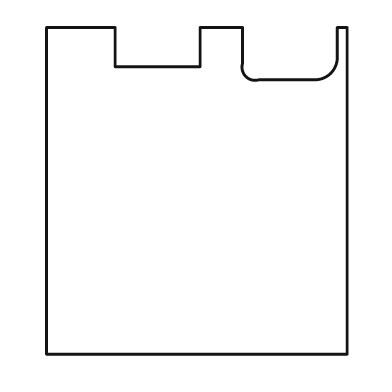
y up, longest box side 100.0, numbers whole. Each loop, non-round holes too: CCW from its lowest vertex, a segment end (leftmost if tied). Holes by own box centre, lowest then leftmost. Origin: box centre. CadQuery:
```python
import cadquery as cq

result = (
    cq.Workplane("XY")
    .moveTo(-46.0, -50.0)
    .lineTo(46.0, -50.0)
    .lineTo(46.0, 50.0)
    .lineTo(43.0, 50.0)
    .lineTo(43.0, 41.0)
    .threePointArc((41.0, 36.0), (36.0, 34.0))
    .lineTo(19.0, 34.0)
    .threePointArc((15.0, 35.0), (14.0, 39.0))
    .lineTo(14.0, 50.0)
    .lineTo(1.0, 50.0)
    .lineTo(1.0, 38.0)
    .lineTo(-25.0, 38.0)
    .lineTo(-25.0, 50.0)
    .lineTo(-46.0, 50.0)
    .close()
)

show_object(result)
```